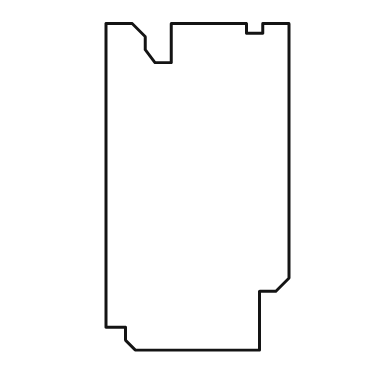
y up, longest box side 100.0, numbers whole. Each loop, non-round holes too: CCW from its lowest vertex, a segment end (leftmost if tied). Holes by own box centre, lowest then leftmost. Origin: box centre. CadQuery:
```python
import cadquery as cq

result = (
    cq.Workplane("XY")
    .moveTo(-19.0, -50.0)
    .lineTo(19.0, -50.0)
    .lineTo(19.0, -32.0)
    .lineTo(24.0, -32.0)
    .lineTo(28.0, -28.0)
    .lineTo(28.0, 50.0)
    .lineTo(20.0, 50.0)
    .lineTo(20.0, 47.0)
    .lineTo(15.0, 47.0)
    .lineTo(15.0, 50.0)
    .lineTo(-8.0, 50.0)
    .lineTo(-8.0, 38.0)
    .lineTo(-13.0, 38.0)
    .lineTo(-16.0, 42.0)
    .lineTo(-16.0, 46.0)
    .lineTo(-20.0, 50.0)
    .lineTo(-28.0, 50.0)
    .lineTo(-28.0, -43.0)
    .lineTo(-22.0, -43.0)
    .lineTo(-22.0, -47.0)
    .close()
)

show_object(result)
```